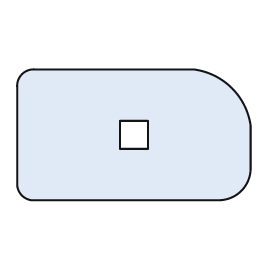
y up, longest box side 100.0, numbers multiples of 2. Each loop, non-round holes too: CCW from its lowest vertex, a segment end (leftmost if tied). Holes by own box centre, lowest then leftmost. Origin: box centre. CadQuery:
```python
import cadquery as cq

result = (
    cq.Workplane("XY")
    .moveTo(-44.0, -28.0)
    .lineTo(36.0, -28.0)
    .threePointArc((46.0, -24.0), (50.0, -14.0))
    .lineTo(50.0, 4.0)
    .threePointArc((42.0, 20.0), (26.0, 28.0))
    .lineTo(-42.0, 28.0)
    .threePointArc((-48.0, 26.0), (-50.0, 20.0))
    .lineTo(-50.0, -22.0)
    .threePointArc((-48.0, -26.0), (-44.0, -28.0))
    .close()
    .moveTo(-6.0, -6.0)
    .lineTo(6.0, -6.0)
    .lineTo(6.0, 6.0)
    .lineTo(-6.0, 6.0)
    .close()
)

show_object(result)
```